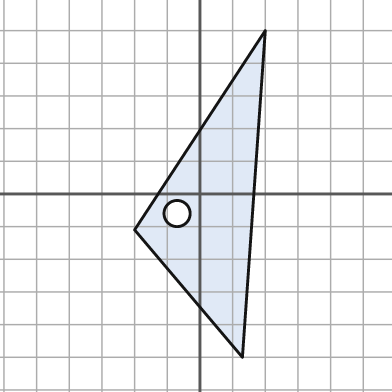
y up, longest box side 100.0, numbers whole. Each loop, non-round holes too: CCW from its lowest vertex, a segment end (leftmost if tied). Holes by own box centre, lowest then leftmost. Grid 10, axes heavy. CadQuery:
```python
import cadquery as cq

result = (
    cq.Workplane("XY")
    .moveTo(13.0, -50.0)
    .lineTo(20.0, 50.0)
    .lineTo(-20.0, -11.0)
    .close()
    .moveTo(-7.0, -6.0)
    .circle(4.0)
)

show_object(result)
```